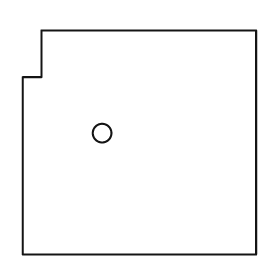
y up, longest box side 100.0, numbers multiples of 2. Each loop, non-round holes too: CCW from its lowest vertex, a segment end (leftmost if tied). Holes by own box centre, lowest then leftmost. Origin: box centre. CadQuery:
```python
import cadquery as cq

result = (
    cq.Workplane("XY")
    .moveTo(-50.0, -48.0)
    .lineTo(50.0, -48.0)
    .lineTo(50.0, 48.0)
    .lineTo(-42.0, 48.0)
    .lineTo(-42.0, 28.0)
    .lineTo(-50.0, 28.0)
    .close()
    .moveTo(-16.0, 4.0)
    .circle(4.0)
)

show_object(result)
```